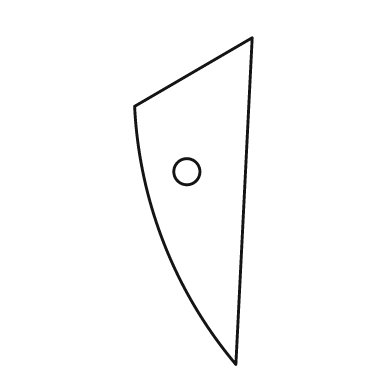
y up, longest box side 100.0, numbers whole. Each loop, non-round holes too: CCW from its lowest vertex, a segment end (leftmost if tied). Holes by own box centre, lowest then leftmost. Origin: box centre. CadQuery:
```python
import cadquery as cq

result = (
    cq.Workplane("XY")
    .moveTo(13.0, -50.0)
    .lineTo(18.0, 50.0)
    .lineTo(-18.0, 29.0)
    .threePointArc((-9.0, -13.0), (13.0, -50.0))
    .close()
    .moveTo(-2.0, 9.0)
    .circle(4.0)
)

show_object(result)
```